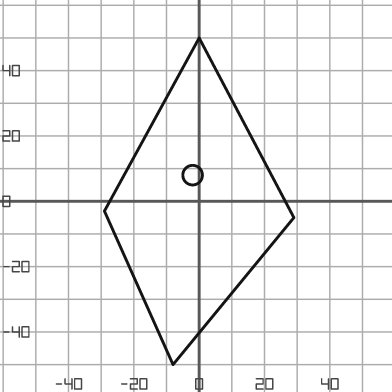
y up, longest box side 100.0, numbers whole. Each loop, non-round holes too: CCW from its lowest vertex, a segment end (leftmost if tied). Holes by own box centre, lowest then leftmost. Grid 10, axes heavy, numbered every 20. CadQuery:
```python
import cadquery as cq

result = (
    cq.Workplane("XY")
    .moveTo(-8.0, -50.0)
    .lineTo(29.0, -5.0)
    .lineTo(0.0, 50.0)
    .lineTo(-29.0, -3.0)
    .close()
    .moveTo(-2.0, 8.0)
    .circle(3.0)
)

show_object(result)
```